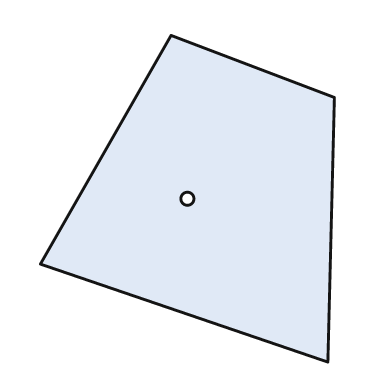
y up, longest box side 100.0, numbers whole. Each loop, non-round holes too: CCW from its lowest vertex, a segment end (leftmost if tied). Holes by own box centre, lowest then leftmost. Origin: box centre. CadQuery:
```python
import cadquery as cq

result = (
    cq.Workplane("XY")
    .moveTo(43.0, -50.0)
    .lineTo(45.0, 31.0)
    .lineTo(-5.0, 50.0)
    .lineTo(-45.0, -20.0)
    .close()
    .moveTo(0.0, 0.0)
    .circle(2.0)
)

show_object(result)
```